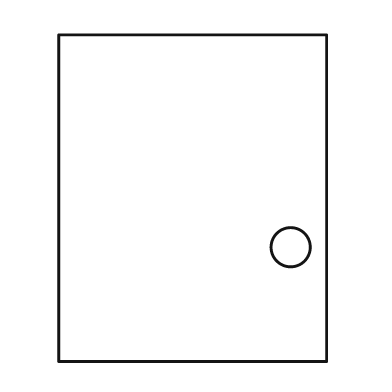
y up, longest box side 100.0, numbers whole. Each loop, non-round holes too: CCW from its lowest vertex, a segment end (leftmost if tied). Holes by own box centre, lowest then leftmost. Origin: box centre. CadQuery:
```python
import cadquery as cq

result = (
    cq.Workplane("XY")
    .moveTo(-41.0, -50.0)
    .lineTo(41.0, -50.0)
    .lineTo(41.0, 50.0)
    .lineTo(-41.0, 50.0)
    .close()
    .moveTo(30.0, -15.0)
    .circle(6.0)
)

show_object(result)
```